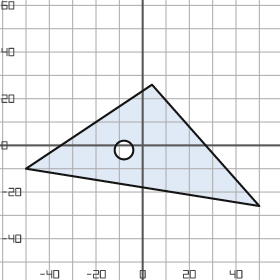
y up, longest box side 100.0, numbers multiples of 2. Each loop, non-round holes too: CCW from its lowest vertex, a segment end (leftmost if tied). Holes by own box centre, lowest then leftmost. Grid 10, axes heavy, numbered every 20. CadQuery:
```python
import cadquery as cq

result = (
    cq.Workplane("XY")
    .moveTo(50.0, -26.0)
    .lineTo(4.0, 26.0)
    .lineTo(-50.0, -10.0)
    .close()
    .moveTo(-8.0, -2.0)
    .circle(4.0)
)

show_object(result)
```